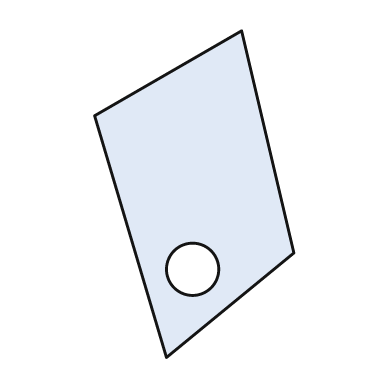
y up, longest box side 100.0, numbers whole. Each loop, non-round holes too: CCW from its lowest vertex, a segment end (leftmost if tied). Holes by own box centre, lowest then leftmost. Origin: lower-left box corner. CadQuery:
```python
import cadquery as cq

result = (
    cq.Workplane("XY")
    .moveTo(22.0, 0.0)
    .lineTo(61.0, 32.0)
    .lineTo(45.0, 100.0)
    .lineTo(0.0, 74.0)
    .close()
    .moveTo(30.0, 27.0)
    .circle(8.0)
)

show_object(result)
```